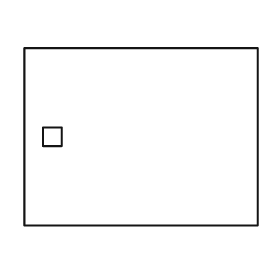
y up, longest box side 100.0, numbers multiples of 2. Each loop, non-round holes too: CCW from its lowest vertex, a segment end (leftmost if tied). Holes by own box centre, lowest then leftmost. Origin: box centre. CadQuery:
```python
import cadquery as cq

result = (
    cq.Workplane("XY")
    .moveTo(-50.0, -38.0)
    .lineTo(50.0, -38.0)
    .lineTo(50.0, 38.0)
    .lineTo(-50.0, 38.0)
    .close()
    .moveTo(-42.0, -4.0)
    .lineTo(-34.0, -4.0)
    .lineTo(-34.0, 4.0)
    .lineTo(-42.0, 4.0)
    .close()
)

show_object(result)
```